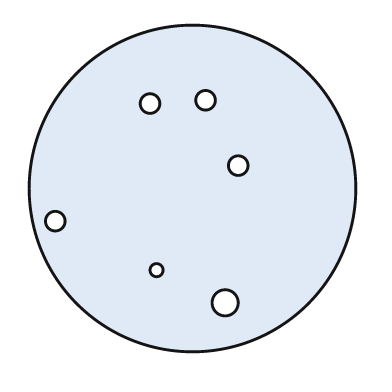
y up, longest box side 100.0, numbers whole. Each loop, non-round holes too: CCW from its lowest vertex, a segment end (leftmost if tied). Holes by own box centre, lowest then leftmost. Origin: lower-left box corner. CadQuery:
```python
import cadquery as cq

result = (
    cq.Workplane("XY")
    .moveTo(50.0, 50.0)
    .circle(50.0)
    .moveTo(60.0, 15.0)
    .circle(4.0)
    .moveTo(39.0, 25.0)
    .circle(2.0)
    .moveTo(8.0, 40.0)
    .circle(3.0)
    .moveTo(64.0, 57.0)
    .circle(3.0)
    .moveTo(37.0, 76.0)
    .circle(3.0)
    .moveTo(54.0, 77.0)
    .circle(3.0)
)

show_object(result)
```